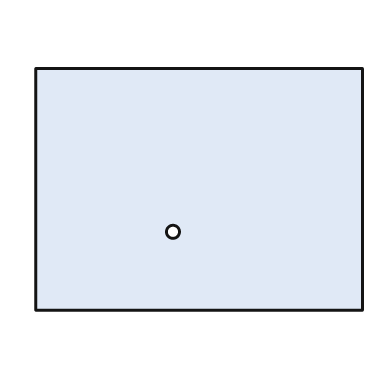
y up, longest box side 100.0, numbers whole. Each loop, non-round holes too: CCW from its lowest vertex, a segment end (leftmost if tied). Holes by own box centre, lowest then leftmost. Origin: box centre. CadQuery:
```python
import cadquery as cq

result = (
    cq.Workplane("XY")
    .moveTo(-50.0, -37.0)
    .lineTo(50.0, -37.0)
    .lineTo(50.0, 37.0)
    .lineTo(-50.0, 37.0)
    .close()
    .moveTo(-8.0, -13.0)
    .circle(2.0)
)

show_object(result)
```